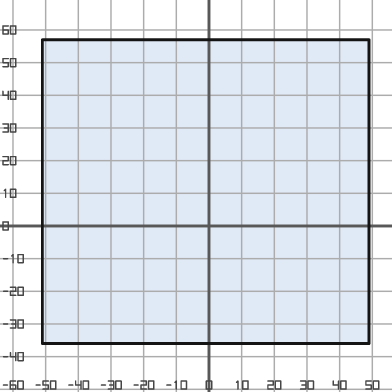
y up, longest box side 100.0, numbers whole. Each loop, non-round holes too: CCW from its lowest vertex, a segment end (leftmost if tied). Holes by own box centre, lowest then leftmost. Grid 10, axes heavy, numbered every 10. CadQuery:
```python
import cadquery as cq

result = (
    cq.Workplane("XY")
    .moveTo(-51.0, -36.0)
    .lineTo(49.0, -36.0)
    .lineTo(49.0, 57.0)
    .lineTo(-51.0, 57.0)
    .close()
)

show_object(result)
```